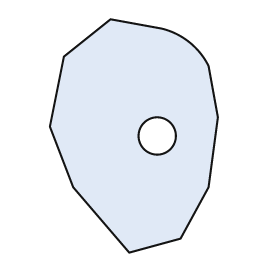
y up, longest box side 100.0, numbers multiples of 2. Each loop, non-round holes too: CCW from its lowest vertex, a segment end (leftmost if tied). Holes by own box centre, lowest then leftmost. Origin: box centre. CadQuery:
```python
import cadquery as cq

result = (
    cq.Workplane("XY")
    .moveTo(-2.0, -50.0)
    .lineTo(20.0, -44.0)
    .lineTo(32.0, -22.0)
    .lineTo(36.0, 8.0)
    .lineTo(32.0, 30.0)
    .threePointArc((24.0, 40.0), (12.0, 46.0))
    .lineTo(-10.0, 50.0)
    .lineTo(-30.0, 34.0)
    .lineTo(-36.0, 4.0)
    .lineTo(-26.0, -22.0)
    .close()
    .moveTo(10.0, 0.0)
    .circle(8.0)
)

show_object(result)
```